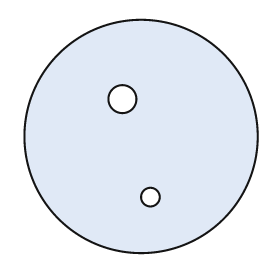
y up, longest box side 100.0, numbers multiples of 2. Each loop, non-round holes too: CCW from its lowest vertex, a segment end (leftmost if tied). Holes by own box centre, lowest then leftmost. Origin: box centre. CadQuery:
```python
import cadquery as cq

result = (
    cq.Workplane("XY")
    .moveTo(0.0, 0.0)
    .circle(50.0)
    .moveTo(4.0, -26.0)
    .circle(4.0)
    .moveTo(-8.0, 16.0)
    .circle(6.0)
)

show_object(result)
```